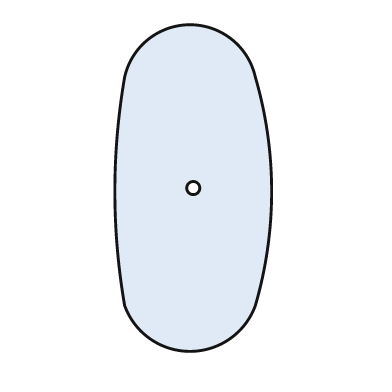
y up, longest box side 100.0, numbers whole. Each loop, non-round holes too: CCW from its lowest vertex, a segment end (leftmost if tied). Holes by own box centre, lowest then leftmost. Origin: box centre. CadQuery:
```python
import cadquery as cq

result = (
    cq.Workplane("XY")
    .moveTo(-21.0, -36.0)
    .threePointArc((-1.0, -50.0), (19.0, -36.0))
    .threePointArc((24.0, -1.0), (19.0, 34.0))
    .threePointArc((-1.0, 50.0), (-21.0, 34.0))
    .threePointArc((-24.0, -1.0), (-21.0, -36.0))
    .close()
    .moveTo(0.0, 0.0)
    .circle(2.0)
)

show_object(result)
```